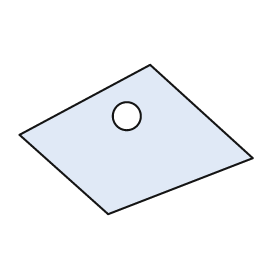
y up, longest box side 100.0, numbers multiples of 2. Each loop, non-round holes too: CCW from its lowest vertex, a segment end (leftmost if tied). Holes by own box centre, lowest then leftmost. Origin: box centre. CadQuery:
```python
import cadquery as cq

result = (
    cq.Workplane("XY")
    .moveTo(-12.0, -32.0)
    .lineTo(50.0, -8.0)
    .lineTo(6.0, 32.0)
    .lineTo(-50.0, 2.0)
    .close()
    .moveTo(-4.0, 10.0)
    .circle(6.0)
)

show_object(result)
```